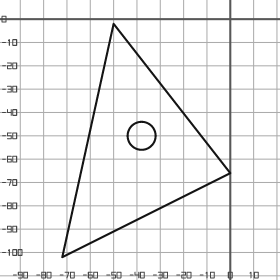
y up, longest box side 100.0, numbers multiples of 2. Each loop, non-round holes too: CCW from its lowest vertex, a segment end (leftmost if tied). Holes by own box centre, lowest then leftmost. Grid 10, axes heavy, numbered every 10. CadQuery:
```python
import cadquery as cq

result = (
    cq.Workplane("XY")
    .moveTo(-72.0, -102.0)
    .lineTo(0.0, -66.0)
    .lineTo(-50.0, -2.0)
    .close()
    .moveTo(-38.0, -50.0)
    .circle(6.0)
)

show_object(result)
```